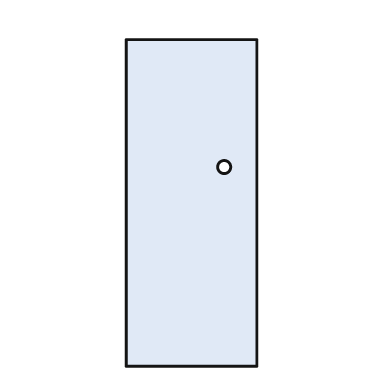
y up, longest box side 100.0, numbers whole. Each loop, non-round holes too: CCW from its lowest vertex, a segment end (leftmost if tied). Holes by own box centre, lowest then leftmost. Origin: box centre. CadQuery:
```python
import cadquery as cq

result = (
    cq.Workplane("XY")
    .moveTo(-20.0, -50.0)
    .lineTo(20.0, -50.0)
    .lineTo(20.0, 50.0)
    .lineTo(-20.0, 50.0)
    .close()
    .moveTo(10.0, 11.0)
    .circle(2.0)
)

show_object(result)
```